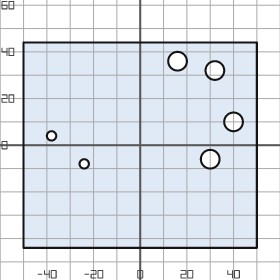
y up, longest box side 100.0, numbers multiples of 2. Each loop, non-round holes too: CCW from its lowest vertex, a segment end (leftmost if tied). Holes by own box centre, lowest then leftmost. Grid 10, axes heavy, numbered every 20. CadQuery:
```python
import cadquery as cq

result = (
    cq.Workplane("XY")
    .moveTo(-50.0, -44.0)
    .lineTo(50.0, -44.0)
    .lineTo(50.0, 44.0)
    .lineTo(-50.0, 44.0)
    .close()
    .moveTo(-24.0, -8.0)
    .circle(2.0)
    .moveTo(30.0, -6.0)
    .circle(4.0)
    .moveTo(-38.0, 4.0)
    .circle(2.0)
    .moveTo(40.0, 10.0)
    .circle(4.0)
    .moveTo(32.0, 32.0)
    .circle(4.0)
    .moveTo(16.0, 36.0)
    .circle(4.0)
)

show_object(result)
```